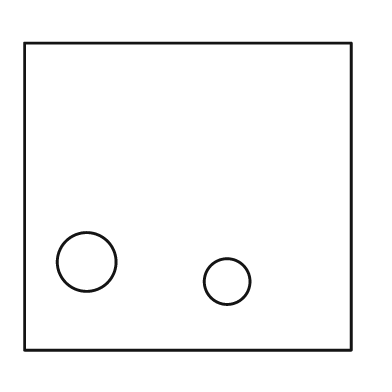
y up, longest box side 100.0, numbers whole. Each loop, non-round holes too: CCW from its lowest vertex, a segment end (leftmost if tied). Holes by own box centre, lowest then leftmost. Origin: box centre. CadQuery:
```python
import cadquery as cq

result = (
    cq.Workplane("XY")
    .moveTo(-50.0, -47.0)
    .lineTo(50.0, -47.0)
    .lineTo(50.0, 47.0)
    .lineTo(-50.0, 47.0)
    .close()
    .moveTo(12.0, -26.0)
    .circle(7.0)
    .moveTo(-31.0, -20.0)
    .circle(9.0)
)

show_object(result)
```